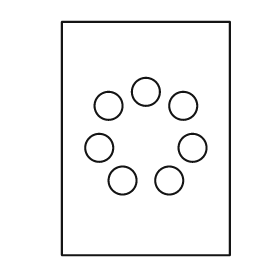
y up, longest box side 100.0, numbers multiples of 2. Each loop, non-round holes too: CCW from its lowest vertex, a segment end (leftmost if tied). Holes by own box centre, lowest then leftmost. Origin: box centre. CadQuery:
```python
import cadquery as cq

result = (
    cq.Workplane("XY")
    .moveTo(-36.0, -50.0)
    .lineTo(36.0, -50.0)
    .lineTo(36.0, 50.0)
    .lineTo(-36.0, 50.0)
    .close()
    .moveTo(-10.0, -18.0)
    .circle(6.0)
    .moveTo(10.0, -18.0)
    .circle(6.0)
    .moveTo(-20.0, -4.0)
    .circle(6.0)
    .moveTo(20.0, -4.0)
    .circle(6.0)
    .moveTo(-16.0, 14.0)
    .circle(6.0)
    .moveTo(16.0, 14.0)
    .circle(6.0)
    .moveTo(0.0, 20.0)
    .circle(6.0)
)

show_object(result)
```